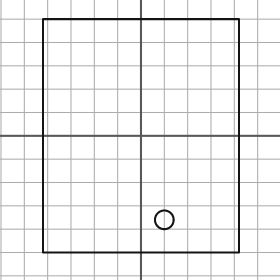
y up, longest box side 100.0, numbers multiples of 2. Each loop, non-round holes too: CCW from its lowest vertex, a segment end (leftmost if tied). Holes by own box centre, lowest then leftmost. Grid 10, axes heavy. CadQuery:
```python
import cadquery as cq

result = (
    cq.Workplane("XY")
    .moveTo(-42.0, -50.0)
    .lineTo(42.0, -50.0)
    .lineTo(42.0, 50.0)
    .lineTo(-42.0, 50.0)
    .close()
    .moveTo(10.0, -36.0)
    .circle(4.0)
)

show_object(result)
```